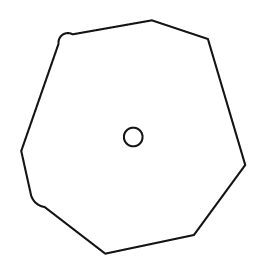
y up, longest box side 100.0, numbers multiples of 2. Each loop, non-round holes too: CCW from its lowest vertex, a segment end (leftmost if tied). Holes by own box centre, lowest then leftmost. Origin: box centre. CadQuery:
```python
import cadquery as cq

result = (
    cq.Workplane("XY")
    .moveTo(-12.0, -50.0)
    .lineTo(26.0, -42.0)
    .lineTo(48.0, -12.0)
    .lineTo(32.0, 42.0)
    .lineTo(8.0, 50.0)
    .lineTo(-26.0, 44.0)
    .threePointArc((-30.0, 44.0), (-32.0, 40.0))
    .lineTo(-48.0, -6.0)
    .lineTo(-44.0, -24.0)
    .threePointArc((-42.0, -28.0), (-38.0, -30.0))
    .close()
    .moveTo(0.0, 0.0)
    .circle(4.0)
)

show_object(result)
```